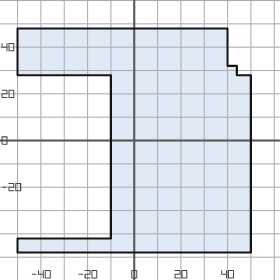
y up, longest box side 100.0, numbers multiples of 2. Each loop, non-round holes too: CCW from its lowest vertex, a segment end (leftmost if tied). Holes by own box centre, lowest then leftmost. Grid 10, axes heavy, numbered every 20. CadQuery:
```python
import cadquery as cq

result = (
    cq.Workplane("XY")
    .moveTo(-50.0, -48.0)
    .lineTo(50.0, -48.0)
    .lineTo(50.0, 28.0)
    .lineTo(44.0, 28.0)
    .lineTo(44.0, 32.0)
    .lineTo(40.0, 32.0)
    .lineTo(40.0, 48.0)
    .lineTo(-50.0, 48.0)
    .lineTo(-50.0, 28.0)
    .lineTo(-10.0, 28.0)
    .lineTo(-10.0, -42.0)
    .lineTo(-50.0, -42.0)
    .close()
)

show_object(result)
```